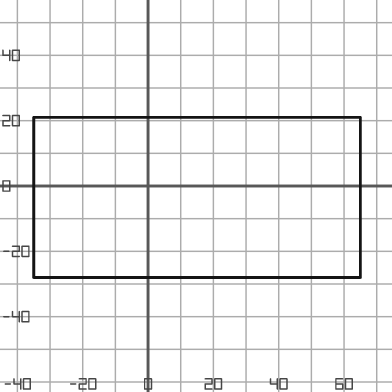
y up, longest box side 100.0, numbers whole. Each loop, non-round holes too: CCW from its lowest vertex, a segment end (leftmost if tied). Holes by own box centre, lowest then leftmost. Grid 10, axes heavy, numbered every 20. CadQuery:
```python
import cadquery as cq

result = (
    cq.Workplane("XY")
    .moveTo(-35.0, -28.0)
    .lineTo(65.0, -28.0)
    .lineTo(65.0, 21.0)
    .lineTo(-35.0, 21.0)
    .close()
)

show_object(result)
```